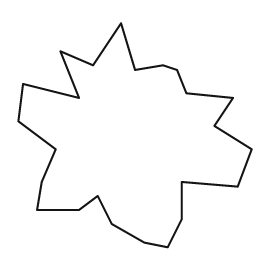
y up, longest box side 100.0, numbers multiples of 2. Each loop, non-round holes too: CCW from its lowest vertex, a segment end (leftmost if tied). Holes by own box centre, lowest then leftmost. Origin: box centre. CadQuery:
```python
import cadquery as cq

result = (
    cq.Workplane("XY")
    .moveTo(14.0, -48.0)
    .lineTo(20.0, -36.0)
    .lineTo(20.0, -20.0)
    .lineTo(44.0, -22.0)
    .lineTo(50.0, -6.0)
    .lineTo(34.0, 4.0)
    .lineTo(42.0, 16.0)
    .lineTo(22.0, 18.0)
    .lineTo(18.0, 28.0)
    .lineTo(12.0, 30.0)
    .lineTo(0.0, 28.0)
    .lineTo(-6.0, 48.0)
    .lineTo(-18.0, 30.0)
    .lineTo(-32.0, 36.0)
    .lineTo(-24.0, 16.0)
    .lineTo(-48.0, 22.0)
    .lineTo(-50.0, 6.0)
    .lineTo(-34.0, -6.0)
    .lineTo(-40.0, -20.0)
    .lineTo(-42.0, -32.0)
    .lineTo(-24.0, -32.0)
    .lineTo(-16.0, -26.0)
    .lineTo(-10.0, -38.0)
    .lineTo(4.0, -46.0)
    .close()
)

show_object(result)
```